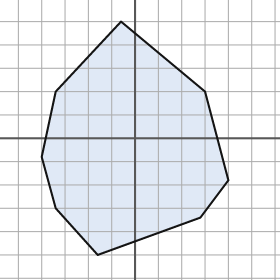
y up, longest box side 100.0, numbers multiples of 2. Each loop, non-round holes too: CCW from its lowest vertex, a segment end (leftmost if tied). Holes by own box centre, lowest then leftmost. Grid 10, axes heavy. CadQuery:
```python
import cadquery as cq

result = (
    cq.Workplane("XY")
    .moveTo(-16.0, -50.0)
    .lineTo(28.0, -34.0)
    .lineTo(40.0, -18.0)
    .lineTo(30.0, 20.0)
    .lineTo(-6.0, 50.0)
    .lineTo(-34.0, 20.0)
    .lineTo(-40.0, -8.0)
    .lineTo(-34.0, -30.0)
    .close()
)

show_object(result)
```